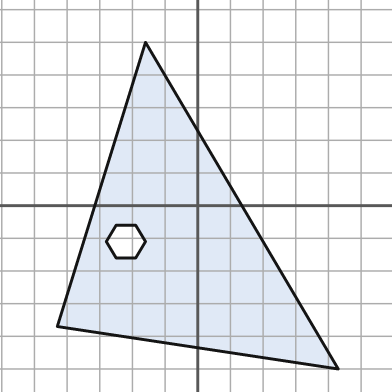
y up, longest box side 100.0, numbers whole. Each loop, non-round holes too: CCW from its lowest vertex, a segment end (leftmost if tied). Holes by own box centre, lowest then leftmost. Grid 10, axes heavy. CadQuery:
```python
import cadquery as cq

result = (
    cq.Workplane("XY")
    .moveTo(43.0, -50.0)
    .lineTo(-16.0, 50.0)
    .lineTo(-43.0, -37.0)
    .close()
    .moveTo(-25.0, -16.0)
    .lineTo(-19.0, -16.0)
    .lineTo(-16.0, -11.0)
    .lineTo(-19.0, -6.0)
    .lineTo(-25.0, -6.0)
    .lineTo(-28.0, -11.0)
    .close()
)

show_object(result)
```